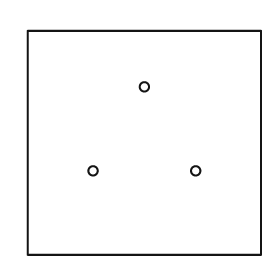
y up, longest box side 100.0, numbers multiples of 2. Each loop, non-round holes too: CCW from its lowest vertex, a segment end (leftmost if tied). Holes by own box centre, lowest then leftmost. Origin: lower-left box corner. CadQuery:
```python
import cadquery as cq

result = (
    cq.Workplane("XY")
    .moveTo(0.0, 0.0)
    .lineTo(100.0, 0.0)
    .lineTo(100.0, 96.0)
    .lineTo(0.0, 96.0)
    .close()
    .moveTo(28.0, 36.0)
    .circle(2.0)
    .moveTo(72.0, 36.0)
    .circle(2.0)
    .moveTo(50.0, 72.0)
    .circle(2.0)
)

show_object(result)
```